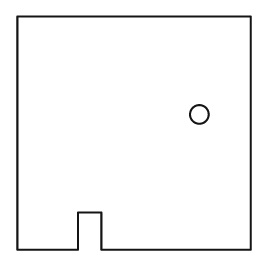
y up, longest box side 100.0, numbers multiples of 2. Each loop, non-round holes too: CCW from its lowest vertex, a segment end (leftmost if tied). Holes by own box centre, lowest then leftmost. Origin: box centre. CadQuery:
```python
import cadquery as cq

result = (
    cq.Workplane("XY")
    .moveTo(-50.0, -50.0)
    .lineTo(-24.0, -50.0)
    .lineTo(-24.0, -34.0)
    .lineTo(-14.0, -34.0)
    .lineTo(-14.0, -50.0)
    .lineTo(50.0, -50.0)
    .lineTo(50.0, 50.0)
    .lineTo(-50.0, 50.0)
    .close()
    .moveTo(28.0, 8.0)
    .circle(4.0)
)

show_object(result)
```